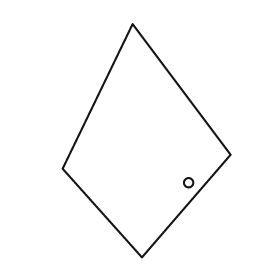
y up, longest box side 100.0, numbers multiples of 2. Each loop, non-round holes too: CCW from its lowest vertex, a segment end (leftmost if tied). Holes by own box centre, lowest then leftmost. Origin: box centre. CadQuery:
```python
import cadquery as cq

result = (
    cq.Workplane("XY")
    .moveTo(-2.0, -50.0)
    .lineTo(36.0, -6.0)
    .lineTo(-6.0, 50.0)
    .lineTo(-36.0, -12.0)
    .close()
    .moveTo(18.0, -18.0)
    .circle(2.0)
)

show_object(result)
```